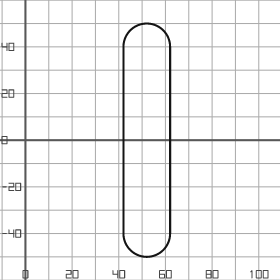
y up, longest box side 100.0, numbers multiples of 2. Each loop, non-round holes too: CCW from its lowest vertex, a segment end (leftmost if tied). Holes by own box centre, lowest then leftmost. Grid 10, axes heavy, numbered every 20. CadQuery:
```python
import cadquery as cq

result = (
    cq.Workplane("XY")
    .moveTo(42.0, -40.0)
    .threePointArc((52.0, -50.0), (62.0, -40.0))
    .lineTo(62.0, 40.0)
    .threePointArc((52.0, 50.0), (42.0, 40.0))
    .close()
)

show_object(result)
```